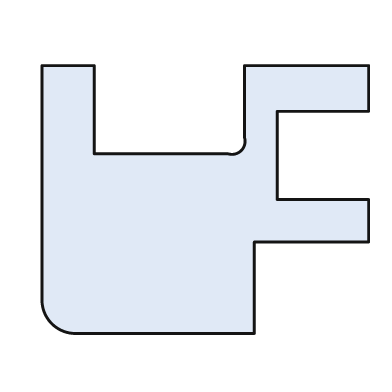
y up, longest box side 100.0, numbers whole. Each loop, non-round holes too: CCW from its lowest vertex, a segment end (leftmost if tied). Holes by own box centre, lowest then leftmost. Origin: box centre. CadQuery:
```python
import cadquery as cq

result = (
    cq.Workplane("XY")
    .moveTo(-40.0, -41.0)
    .lineTo(15.0, -41.0)
    .lineTo(15.0, -13.0)
    .lineTo(50.0, -13.0)
    .lineTo(50.0, 0.0)
    .lineTo(22.0, 0.0)
    .lineTo(22.0, 27.0)
    .lineTo(50.0, 27.0)
    .lineTo(50.0, 41.0)
    .lineTo(12.0, 41.0)
    .lineTo(12.0, 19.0)
    .threePointArc((11.0, 15.0), (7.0, 14.0))
    .lineTo(-34.0, 14.0)
    .lineTo(-34.0, 41.0)
    .lineTo(-50.0, 41.0)
    .lineTo(-50.0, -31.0)
    .threePointArc((-47.0, -38.0), (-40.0, -41.0))
    .close()
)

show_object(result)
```